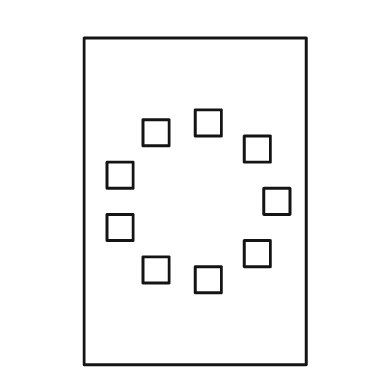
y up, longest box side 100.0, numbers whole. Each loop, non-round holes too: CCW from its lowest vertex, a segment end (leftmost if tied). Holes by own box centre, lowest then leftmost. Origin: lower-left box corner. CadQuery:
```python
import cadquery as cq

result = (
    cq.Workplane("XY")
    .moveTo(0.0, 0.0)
    .lineTo(68.0, 0.0)
    .lineTo(68.0, 100.0)
    .lineTo(0.0, 100.0)
    .close()
    .moveTo(34.0, 22.0)
    .lineTo(42.0, 22.0)
    .lineTo(42.0, 30.0)
    .lineTo(34.0, 30.0)
    .close()
    .moveTo(18.0, 25.0)
    .lineTo(26.0, 25.0)
    .lineTo(26.0, 33.0)
    .lineTo(18.0, 33.0)
    .close()
    .moveTo(49.0, 30.0)
    .lineTo(57.0, 30.0)
    .lineTo(57.0, 38.0)
    .lineTo(49.0, 38.0)
    .close()
    .moveTo(7.0, 38.0)
    .lineTo(15.0, 38.0)
    .lineTo(15.0, 46.0)
    .lineTo(7.0, 46.0)
    .close()
    .moveTo(55.0, 46.0)
    .lineTo(63.0, 46.0)
    .lineTo(63.0, 54.0)
    .lineTo(55.0, 54.0)
    .close()
    .moveTo(7.0, 54.0)
    .lineTo(15.0, 54.0)
    .lineTo(15.0, 62.0)
    .lineTo(7.0, 62.0)
    .close()
    .moveTo(49.0, 62.0)
    .lineTo(57.0, 62.0)
    .lineTo(57.0, 70.0)
    .lineTo(49.0, 70.0)
    .close()
    .moveTo(18.0, 67.0)
    .lineTo(26.0, 67.0)
    .lineTo(26.0, 75.0)
    .lineTo(18.0, 75.0)
    .close()
    .moveTo(34.0, 70.0)
    .lineTo(42.0, 70.0)
    .lineTo(42.0, 78.0)
    .lineTo(34.0, 78.0)
    .close()
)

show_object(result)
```